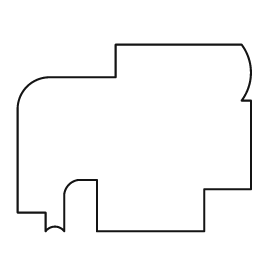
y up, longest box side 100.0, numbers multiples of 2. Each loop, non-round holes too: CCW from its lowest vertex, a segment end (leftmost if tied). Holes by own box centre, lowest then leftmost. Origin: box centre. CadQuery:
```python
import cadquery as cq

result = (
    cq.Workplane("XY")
    .moveTo(-38.0, -40.0)
    .threePointArc((-34.0, -38.0), (-30.0, -40.0))
    .lineTo(-30.0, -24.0)
    .threePointArc((-28.0, -20.0), (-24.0, -18.0))
    .lineTo(-16.0, -18.0)
    .lineTo(-16.0, -40.0)
    .lineTo(30.0, -40.0)
    .lineTo(30.0, -22.0)
    .lineTo(50.0, -22.0)
    .lineTo(50.0, 16.0)
    .lineTo(46.0, 16.0)
    .threePointArc((50.0, 28.0), (46.0, 40.0))
    .lineTo(-8.0, 40.0)
    .lineTo(-8.0, 26.0)
    .lineTo(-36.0, 26.0)
    .threePointArc((-46.0, 22.0), (-50.0, 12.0))
    .lineTo(-50.0, -32.0)
    .lineTo(-38.0, -32.0)
    .close()
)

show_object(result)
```